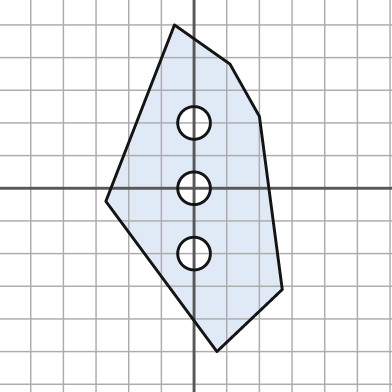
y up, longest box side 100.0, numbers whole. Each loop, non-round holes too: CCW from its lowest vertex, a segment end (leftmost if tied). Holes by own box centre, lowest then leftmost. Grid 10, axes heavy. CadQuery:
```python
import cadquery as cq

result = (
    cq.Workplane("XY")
    .moveTo(7.0, -50.0)
    .lineTo(27.0, -31.0)
    .lineTo(20.0, 22.0)
    .lineTo(11.0, 38.0)
    .lineTo(-6.0, 50.0)
    .lineTo(-27.0, -4.0)
    .close()
    .moveTo(0.0, -20.0)
    .circle(5.0)
    .moveTo(0.0, 0.0)
    .circle(5.0)
    .moveTo(0.0, 20.0)
    .circle(5.0)
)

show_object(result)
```